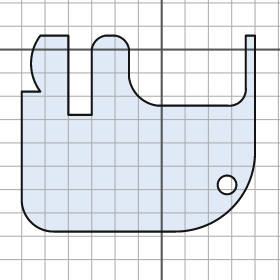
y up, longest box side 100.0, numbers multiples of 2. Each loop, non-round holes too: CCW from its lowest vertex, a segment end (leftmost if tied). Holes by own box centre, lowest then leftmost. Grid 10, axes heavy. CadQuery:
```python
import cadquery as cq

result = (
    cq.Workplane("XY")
    .moveTo(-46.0, -78.0)
    .lineTo(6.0, -78.0)
    .threePointArc((30.0, -68.0), (40.0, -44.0))
    .lineTo(40.0, 6.0)
    .lineTo(36.0, 6.0)
    .lineTo(36.0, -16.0)
    .threePointArc((34.0, -22.0), (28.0, -24.0))
    .lineTo(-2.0, -24.0)
    .threePointArc((-10.0, -20.0), (-14.0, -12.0))
    .lineTo(-14.0, 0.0)
    .threePointArc((-16.0, 4.0), (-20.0, 6.0))
    .lineTo(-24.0, 6.0)
    .threePointArc((-28.0, 4.0), (-30.0, 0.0))
    .lineTo(-30.0, -28.0)
    .lineTo(-40.0, -28.0)
    .lineTo(-40.0, 6.0)
    .lineTo(-52.0, 6.0)
    .threePointArc((-56.0, -6.0), (-52.0, -18.0))
    .lineTo(-60.0, -18.0)
    .lineTo(-60.0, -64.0)
    .threePointArc((-56.0, -74.0), (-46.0, -78.0))
    .close()
    .moveTo(28.0, -58.0)
    .circle(4.0)
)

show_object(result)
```